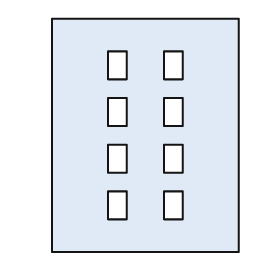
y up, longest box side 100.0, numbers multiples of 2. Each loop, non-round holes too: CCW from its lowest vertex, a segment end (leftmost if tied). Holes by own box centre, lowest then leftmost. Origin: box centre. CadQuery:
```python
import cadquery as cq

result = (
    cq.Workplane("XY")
    .moveTo(-40.0, -50.0)
    .lineTo(40.0, -50.0)
    .lineTo(40.0, 50.0)
    .lineTo(-40.0, 50.0)
    .close()
    .moveTo(-16.0, -36.0)
    .lineTo(-8.0, -36.0)
    .lineTo(-8.0, -24.0)
    .lineTo(-16.0, -24.0)
    .close()
    .moveTo(8.0, -36.0)
    .lineTo(16.0, -36.0)
    .lineTo(16.0, -24.0)
    .lineTo(8.0, -24.0)
    .close()
    .moveTo(-16.0, -16.0)
    .lineTo(-8.0, -16.0)
    .lineTo(-8.0, -4.0)
    .lineTo(-16.0, -4.0)
    .close()
    .moveTo(8.0, -16.0)
    .lineTo(16.0, -16.0)
    .lineTo(16.0, -4.0)
    .lineTo(8.0, -4.0)
    .close()
    .moveTo(-16.0, 4.0)
    .lineTo(-8.0, 4.0)
    .lineTo(-8.0, 16.0)
    .lineTo(-16.0, 16.0)
    .close()
    .moveTo(8.0, 4.0)
    .lineTo(16.0, 4.0)
    .lineTo(16.0, 16.0)
    .lineTo(8.0, 16.0)
    .close()
    .moveTo(-16.0, 24.0)
    .lineTo(-8.0, 24.0)
    .lineTo(-8.0, 36.0)
    .lineTo(-16.0, 36.0)
    .close()
    .moveTo(8.0, 24.0)
    .lineTo(16.0, 24.0)
    .lineTo(16.0, 36.0)
    .lineTo(8.0, 36.0)
    .close()
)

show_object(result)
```